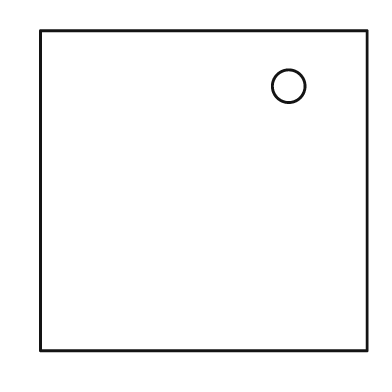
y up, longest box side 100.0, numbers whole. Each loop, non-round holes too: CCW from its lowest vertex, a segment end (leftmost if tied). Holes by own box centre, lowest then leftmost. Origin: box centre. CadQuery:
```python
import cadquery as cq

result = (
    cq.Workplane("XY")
    .moveTo(-50.0, -49.0)
    .lineTo(50.0, -49.0)
    .lineTo(50.0, 49.0)
    .lineTo(-50.0, 49.0)
    .close()
    .moveTo(26.0, 32.0)
    .circle(5.0)
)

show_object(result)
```